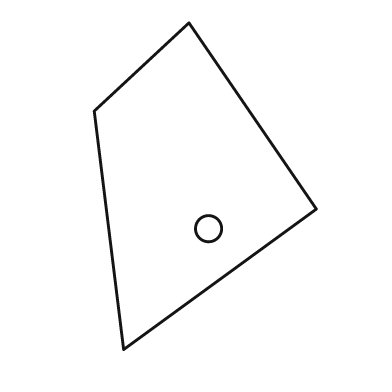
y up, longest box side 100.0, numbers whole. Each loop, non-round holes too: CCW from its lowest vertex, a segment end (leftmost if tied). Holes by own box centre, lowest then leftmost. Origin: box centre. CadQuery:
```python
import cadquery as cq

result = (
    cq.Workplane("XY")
    .moveTo(-25.0, -50.0)
    .lineTo(34.0, -7.0)
    .lineTo(-5.0, 50.0)
    .lineTo(-34.0, 23.0)
    .close()
    .moveTo(1.0, -13.0)
    .circle(4.0)
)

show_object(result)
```